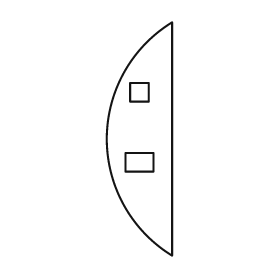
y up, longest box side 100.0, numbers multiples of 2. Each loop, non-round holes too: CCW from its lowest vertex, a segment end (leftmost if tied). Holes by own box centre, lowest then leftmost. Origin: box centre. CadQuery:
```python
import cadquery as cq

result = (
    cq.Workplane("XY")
    .moveTo(14.0, -50.0)
    .lineTo(14.0, 50.0)
    .threePointArc((-14.0, 0.0), (14.0, -50.0))
    .close()
    .moveTo(-6.0, -14.0)
    .lineTo(6.0, -14.0)
    .lineTo(6.0, -6.0)
    .lineTo(-6.0, -6.0)
    .close()
    .moveTo(-4.0, 16.0)
    .lineTo(4.0, 16.0)
    .lineTo(4.0, 24.0)
    .lineTo(-4.0, 24.0)
    .close()
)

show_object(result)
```